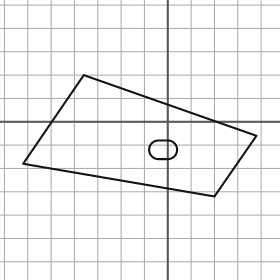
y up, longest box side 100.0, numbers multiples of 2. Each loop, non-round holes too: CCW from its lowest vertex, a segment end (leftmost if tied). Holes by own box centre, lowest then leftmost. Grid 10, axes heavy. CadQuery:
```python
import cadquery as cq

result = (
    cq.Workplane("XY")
    .moveTo(20.0, -32.0)
    .lineTo(38.0, -6.0)
    .lineTo(-36.0, 20.0)
    .lineTo(-62.0, -18.0)
    .close()
    .moveTo(-4.0, -16.0)
    .lineTo(0.0, -16.0)
    .threePointArc((4.0, -12.0), (0.0, -8.0))
    .lineTo(-4.0, -8.0)
    .threePointArc((-8.0, -12.0), (-4.0, -16.0))
    .close()
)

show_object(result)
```